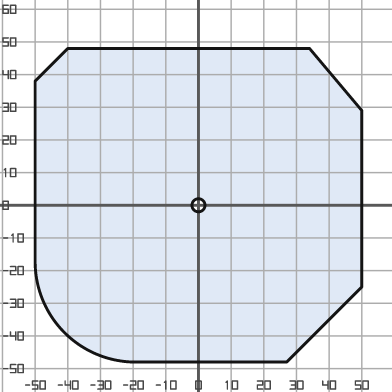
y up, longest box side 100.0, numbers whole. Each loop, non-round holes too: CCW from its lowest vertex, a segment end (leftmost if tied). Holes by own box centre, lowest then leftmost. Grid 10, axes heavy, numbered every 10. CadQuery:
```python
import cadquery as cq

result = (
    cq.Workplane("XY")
    .moveTo(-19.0, -48.0)
    .lineTo(27.0, -48.0)
    .lineTo(50.0, -25.0)
    .lineTo(50.0, 29.0)
    .lineTo(34.0, 48.0)
    .lineTo(-40.0, 48.0)
    .lineTo(-50.0, 38.0)
    .lineTo(-50.0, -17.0)
    .threePointArc((-41.0, -39.0), (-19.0, -48.0))
    .close()
    .moveTo(0.0, 0.0)
    .circle(2.0)
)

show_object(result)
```